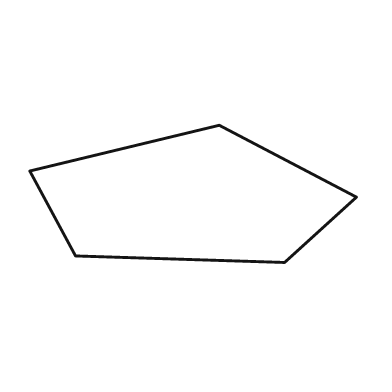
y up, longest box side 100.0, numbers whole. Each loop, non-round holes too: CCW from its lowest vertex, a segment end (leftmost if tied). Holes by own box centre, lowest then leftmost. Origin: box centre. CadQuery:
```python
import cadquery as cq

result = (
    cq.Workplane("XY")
    .moveTo(28.0, -21.0)
    .lineTo(50.0, -1.0)
    .lineTo(8.0, 21.0)
    .lineTo(-50.0, 7.0)
    .lineTo(-36.0, -19.0)
    .close()
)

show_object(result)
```